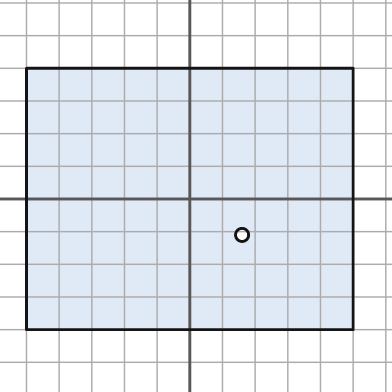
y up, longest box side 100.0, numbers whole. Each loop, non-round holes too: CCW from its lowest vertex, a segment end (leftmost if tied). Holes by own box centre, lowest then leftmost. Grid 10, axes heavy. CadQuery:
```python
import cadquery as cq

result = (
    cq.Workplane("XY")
    .moveTo(-50.0, -40.0)
    .lineTo(50.0, -40.0)
    .lineTo(50.0, 40.0)
    .lineTo(-50.0, 40.0)
    .close()
    .moveTo(16.0, -11.0)
    .circle(2.0)
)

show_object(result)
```